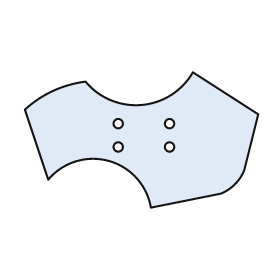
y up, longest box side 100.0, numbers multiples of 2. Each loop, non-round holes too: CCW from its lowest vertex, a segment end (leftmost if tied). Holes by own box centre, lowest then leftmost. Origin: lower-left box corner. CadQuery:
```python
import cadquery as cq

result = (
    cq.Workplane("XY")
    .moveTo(54.0, 0.0)
    .lineTo(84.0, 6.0)
    .threePointArc((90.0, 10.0), (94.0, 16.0))
    .lineTo(100.0, 40.0)
    .lineTo(72.0, 58.0)
    .threePointArc((50.0, 44.0), (26.0, 54.0))
    .threePointArc((12.0, 50.0), (0.0, 42.0))
    .lineTo(10.0, 12.0)
    .threePointArc((36.0, 20.0), (54.0, 0.0))
    .close()
    .moveTo(40.0, 26.0)
    .circle(2.0)
    .moveTo(62.0, 26.0)
    .circle(2.0)
    .moveTo(40.0, 36.0)
    .circle(2.0)
    .moveTo(62.0, 36.0)
    .circle(2.0)
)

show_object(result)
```